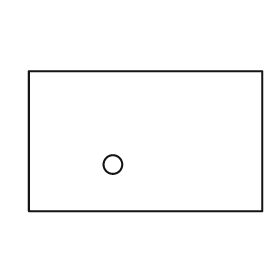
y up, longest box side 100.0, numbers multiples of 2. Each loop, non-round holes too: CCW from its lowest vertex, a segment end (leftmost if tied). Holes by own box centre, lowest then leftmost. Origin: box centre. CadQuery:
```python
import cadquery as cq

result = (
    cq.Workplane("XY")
    .moveTo(-50.0, -30.0)
    .lineTo(50.0, -30.0)
    .lineTo(50.0, 30.0)
    .lineTo(-50.0, 30.0)
    .close()
    .moveTo(-14.0, -10.0)
    .circle(4.0)
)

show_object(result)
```